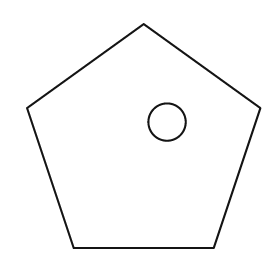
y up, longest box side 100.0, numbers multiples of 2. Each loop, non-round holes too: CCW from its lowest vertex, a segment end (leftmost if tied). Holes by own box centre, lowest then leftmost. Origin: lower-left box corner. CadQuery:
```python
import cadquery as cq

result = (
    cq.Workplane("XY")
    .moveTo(20.0, 0.0)
    .lineTo(80.0, 0.0)
    .lineTo(100.0, 60.0)
    .lineTo(50.0, 96.0)
    .lineTo(0.0, 60.0)
    .close()
    .moveTo(60.0, 54.0)
    .circle(8.0)
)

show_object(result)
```